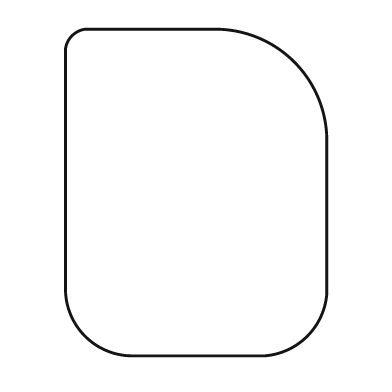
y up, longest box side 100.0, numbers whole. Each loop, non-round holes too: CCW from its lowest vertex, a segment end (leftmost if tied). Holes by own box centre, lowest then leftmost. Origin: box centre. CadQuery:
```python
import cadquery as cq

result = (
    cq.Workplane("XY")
    .moveTo(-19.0, -50.0)
    .lineTo(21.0, -50.0)
    .threePointArc((34.0, -44.0), (40.0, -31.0))
    .lineTo(40.0, 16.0)
    .threePointArc((30.0, 40.0), (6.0, 50.0))
    .lineTo(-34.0, 50.0)
    .threePointArc((-38.0, 48.0), (-40.0, 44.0))
    .lineTo(-40.0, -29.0)
    .threePointArc((-34.0, -44.0), (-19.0, -50.0))
    .close()
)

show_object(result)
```